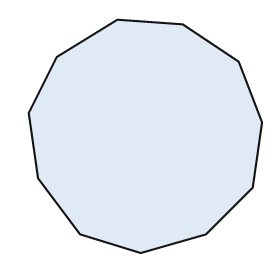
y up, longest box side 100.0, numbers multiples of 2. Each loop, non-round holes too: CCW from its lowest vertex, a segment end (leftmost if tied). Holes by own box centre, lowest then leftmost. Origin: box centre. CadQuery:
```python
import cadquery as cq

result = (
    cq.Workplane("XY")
    .moveTo(-2.0, -50.0)
    .lineTo(26.0, -42.0)
    .lineTo(46.0, -22.0)
    .lineTo(50.0, 6.0)
    .lineTo(40.0, 32.0)
    .lineTo(16.0, 48.0)
    .lineTo(-12.0, 50.0)
    .lineTo(-38.0, 34.0)
    .lineTo(-50.0, 10.0)
    .lineTo(-46.0, -18.0)
    .lineTo(-28.0, -42.0)
    .close()
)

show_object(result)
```